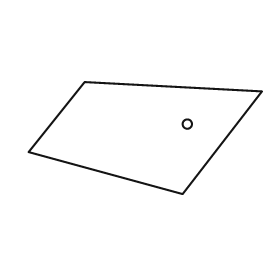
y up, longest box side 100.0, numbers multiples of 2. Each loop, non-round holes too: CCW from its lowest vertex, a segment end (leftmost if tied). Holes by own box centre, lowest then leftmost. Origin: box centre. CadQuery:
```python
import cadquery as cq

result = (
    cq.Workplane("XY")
    .moveTo(16.0, -24.0)
    .lineTo(50.0, 20.0)
    .lineTo(-26.0, 24.0)
    .lineTo(-50.0, -6.0)
    .close()
    .moveTo(18.0, 6.0)
    .circle(2.0)
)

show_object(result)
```